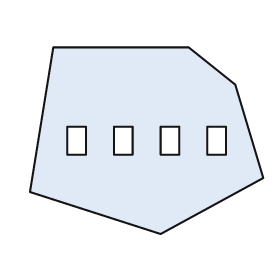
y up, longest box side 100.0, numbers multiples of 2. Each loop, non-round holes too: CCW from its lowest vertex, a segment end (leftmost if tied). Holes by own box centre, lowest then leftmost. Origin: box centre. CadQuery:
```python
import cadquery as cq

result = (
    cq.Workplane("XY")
    .moveTo(6.0, -40.0)
    .lineTo(50.0, -16.0)
    .lineTo(38.0, 24.0)
    .lineTo(18.0, 40.0)
    .lineTo(-40.0, 40.0)
    .lineTo(-50.0, -22.0)
    .close()
    .moveTo(-34.0, -6.0)
    .lineTo(-26.0, -6.0)
    .lineTo(-26.0, 6.0)
    .lineTo(-34.0, 6.0)
    .close()
    .moveTo(-14.0, -6.0)
    .lineTo(-6.0, -6.0)
    .lineTo(-6.0, 6.0)
    .lineTo(-14.0, 6.0)
    .close()
    .moveTo(6.0, -6.0)
    .lineTo(14.0, -6.0)
    .lineTo(14.0, 6.0)
    .lineTo(6.0, 6.0)
    .close()
    .moveTo(26.0, -6.0)
    .lineTo(34.0, -6.0)
    .lineTo(34.0, 6.0)
    .lineTo(26.0, 6.0)
    .close()
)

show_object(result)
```